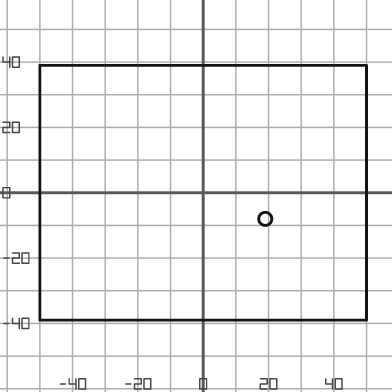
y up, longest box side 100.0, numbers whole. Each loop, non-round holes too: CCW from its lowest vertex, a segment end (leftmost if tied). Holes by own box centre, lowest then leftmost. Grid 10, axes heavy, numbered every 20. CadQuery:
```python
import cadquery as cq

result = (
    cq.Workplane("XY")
    .moveTo(-50.0, -39.0)
    .lineTo(50.0, -39.0)
    .lineTo(50.0, 39.0)
    .lineTo(-50.0, 39.0)
    .close()
    .moveTo(19.0, -8.0)
    .circle(2.0)
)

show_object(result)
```